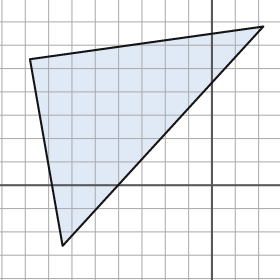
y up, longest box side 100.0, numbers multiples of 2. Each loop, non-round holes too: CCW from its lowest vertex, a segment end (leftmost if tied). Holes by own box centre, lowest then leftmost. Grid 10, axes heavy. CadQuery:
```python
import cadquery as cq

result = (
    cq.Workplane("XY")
    .moveTo(-64.0, -26.0)
    .lineTo(22.0, 68.0)
    .lineTo(-78.0, 54.0)
    .close()
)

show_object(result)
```